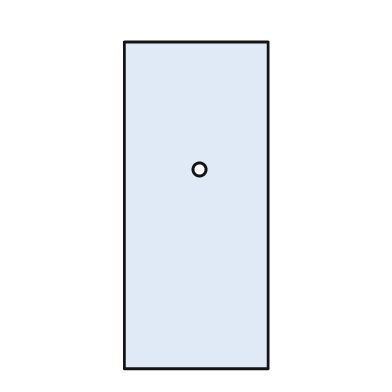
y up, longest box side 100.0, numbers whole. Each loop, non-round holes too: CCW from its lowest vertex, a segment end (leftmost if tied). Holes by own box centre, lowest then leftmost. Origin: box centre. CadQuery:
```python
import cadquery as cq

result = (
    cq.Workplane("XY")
    .moveTo(-22.0, -50.0)
    .lineTo(22.0, -50.0)
    .lineTo(22.0, 50.0)
    .lineTo(-22.0, 50.0)
    .close()
    .moveTo(1.0, 11.0)
    .circle(2.0)
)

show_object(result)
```